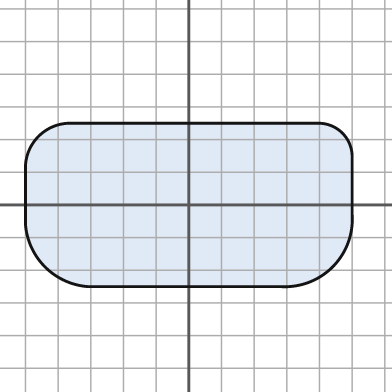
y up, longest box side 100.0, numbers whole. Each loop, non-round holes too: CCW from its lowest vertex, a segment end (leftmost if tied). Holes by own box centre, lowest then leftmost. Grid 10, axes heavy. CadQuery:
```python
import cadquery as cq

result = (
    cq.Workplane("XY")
    .moveTo(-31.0, -25.0)
    .lineTo(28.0, -25.0)
    .threePointArc((44.0, -19.0), (50.0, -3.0))
    .lineTo(50.0, 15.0)
    .threePointArc((47.0, 22.0), (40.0, 25.0))
    .lineTo(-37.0, 25.0)
    .threePointArc((-46.0, 21.0), (-50.0, 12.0))
    .lineTo(-50.0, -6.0)
    .threePointArc((-44.0, -19.0), (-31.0, -25.0))
    .close()
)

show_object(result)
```